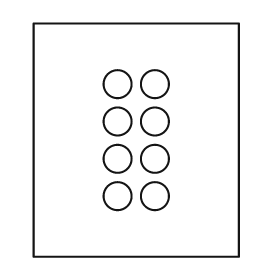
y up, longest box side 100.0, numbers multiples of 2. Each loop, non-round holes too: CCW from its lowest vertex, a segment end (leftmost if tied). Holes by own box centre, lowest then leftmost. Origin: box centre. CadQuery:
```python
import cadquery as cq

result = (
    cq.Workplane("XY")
    .moveTo(-44.0, -50.0)
    .lineTo(44.0, -50.0)
    .lineTo(44.0, 50.0)
    .lineTo(-44.0, 50.0)
    .close()
    .moveTo(-8.0, -24.0)
    .circle(6.0)
    .moveTo(8.0, -24.0)
    .circle(6.0)
    .moveTo(-8.0, -8.0)
    .circle(6.0)
    .moveTo(8.0, -8.0)
    .circle(6.0)
    .moveTo(-8.0, 8.0)
    .circle(6.0)
    .moveTo(8.0, 8.0)
    .circle(6.0)
    .moveTo(-8.0, 24.0)
    .circle(6.0)
    .moveTo(8.0, 24.0)
    .circle(6.0)
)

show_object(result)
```